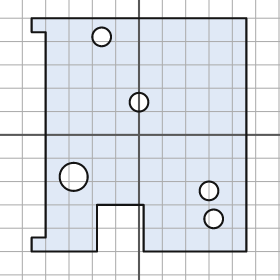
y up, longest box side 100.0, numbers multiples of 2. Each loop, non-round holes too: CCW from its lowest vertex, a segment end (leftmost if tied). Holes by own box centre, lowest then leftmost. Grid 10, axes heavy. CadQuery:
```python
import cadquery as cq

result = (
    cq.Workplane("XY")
    .moveTo(-46.0, -50.0)
    .lineTo(-18.0, -50.0)
    .lineTo(-18.0, -30.0)
    .lineTo(2.0, -30.0)
    .lineTo(2.0, -50.0)
    .lineTo(46.0, -50.0)
    .lineTo(46.0, 50.0)
    .lineTo(-46.0, 50.0)
    .lineTo(-46.0, 44.0)
    .lineTo(-40.0, 44.0)
    .lineTo(-40.0, -44.0)
    .lineTo(-46.0, -44.0)
    .close()
    .moveTo(32.0, -36.0)
    .circle(4.0)
    .moveTo(30.0, -24.0)
    .circle(4.0)
    .moveTo(-28.0, -18.0)
    .circle(6.0)
    .moveTo(0.0, 14.0)
    .circle(4.0)
    .moveTo(-16.0, 42.0)
    .circle(4.0)
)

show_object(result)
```